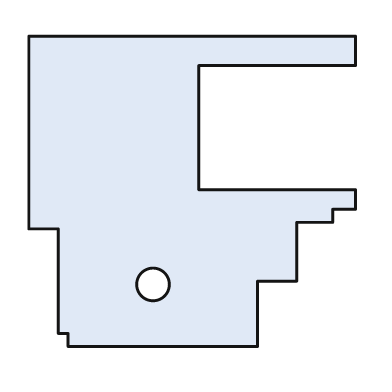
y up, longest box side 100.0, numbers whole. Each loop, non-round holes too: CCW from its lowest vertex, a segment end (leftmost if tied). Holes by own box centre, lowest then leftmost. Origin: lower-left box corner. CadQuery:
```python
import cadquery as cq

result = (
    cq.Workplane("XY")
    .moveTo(12.0, 0.0)
    .lineTo(70.0, 0.0)
    .lineTo(70.0, 20.0)
    .lineTo(82.0, 20.0)
    .lineTo(82.0, 38.0)
    .lineTo(93.0, 38.0)
    .lineTo(93.0, 42.0)
    .lineTo(100.0, 42.0)
    .lineTo(100.0, 48.0)
    .lineTo(52.0, 48.0)
    .lineTo(52.0, 86.0)
    .lineTo(100.0, 86.0)
    .lineTo(100.0, 95.0)
    .lineTo(0.0, 95.0)
    .lineTo(0.0, 36.0)
    .lineTo(9.0, 36.0)
    .lineTo(9.0, 4.0)
    .lineTo(12.0, 4.0)
    .close()
    .moveTo(38.0, 19.0)
    .circle(5.0)
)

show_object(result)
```